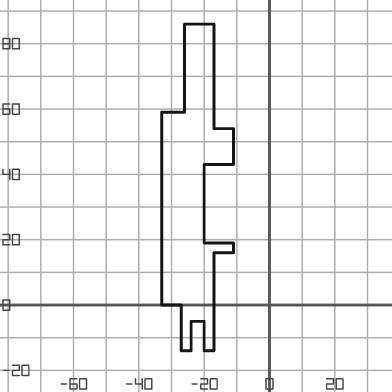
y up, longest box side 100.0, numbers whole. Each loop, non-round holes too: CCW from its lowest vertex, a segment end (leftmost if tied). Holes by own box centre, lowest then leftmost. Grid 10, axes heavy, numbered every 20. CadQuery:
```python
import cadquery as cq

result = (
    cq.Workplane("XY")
    .moveTo(-27.0, -14.0)
    .lineTo(-24.0, -14.0)
    .lineTo(-24.0, -5.0)
    .lineTo(-20.0, -5.0)
    .lineTo(-20.0, -14.0)
    .lineTo(-17.0, -14.0)
    .lineTo(-17.0, 16.0)
    .lineTo(-11.0, 16.0)
    .lineTo(-11.0, 19.0)
    .lineTo(-20.0, 19.0)
    .lineTo(-20.0, 43.0)
    .lineTo(-11.0, 43.0)
    .lineTo(-11.0, 54.0)
    .lineTo(-17.0, 54.0)
    .lineTo(-17.0, 86.0)
    .lineTo(-26.0, 86.0)
    .lineTo(-26.0, 59.0)
    .lineTo(-33.0, 59.0)
    .lineTo(-33.0, 0.0)
    .lineTo(-27.0, 0.0)
    .close()
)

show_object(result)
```